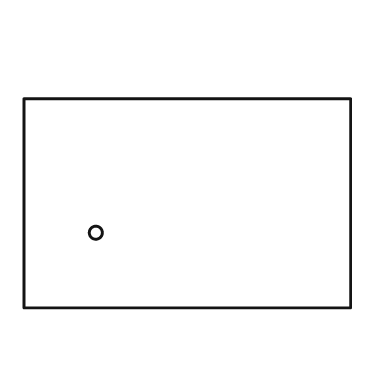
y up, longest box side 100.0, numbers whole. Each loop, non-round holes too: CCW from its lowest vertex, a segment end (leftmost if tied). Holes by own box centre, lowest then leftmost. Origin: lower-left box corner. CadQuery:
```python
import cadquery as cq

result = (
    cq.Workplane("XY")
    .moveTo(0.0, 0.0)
    .lineTo(100.0, 0.0)
    .lineTo(100.0, 64.0)
    .lineTo(0.0, 64.0)
    .close()
    .moveTo(22.0, 23.0)
    .circle(2.0)
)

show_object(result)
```